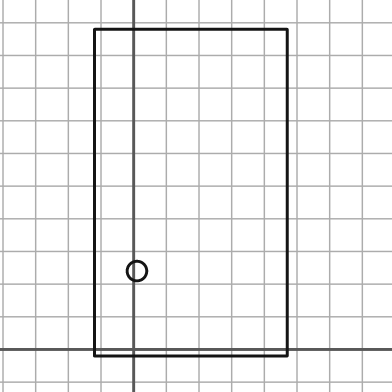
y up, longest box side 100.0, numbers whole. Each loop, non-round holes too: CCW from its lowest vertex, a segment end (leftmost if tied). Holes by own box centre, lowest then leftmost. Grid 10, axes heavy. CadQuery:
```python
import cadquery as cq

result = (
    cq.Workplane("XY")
    .moveTo(-12.0, -2.0)
    .lineTo(47.0, -2.0)
    .lineTo(47.0, 98.0)
    .lineTo(-12.0, 98.0)
    .close()
    .moveTo(1.0, 24.0)
    .circle(3.0)
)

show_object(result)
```